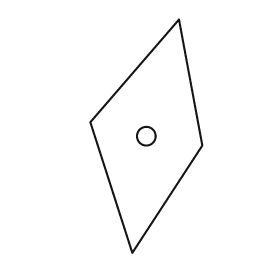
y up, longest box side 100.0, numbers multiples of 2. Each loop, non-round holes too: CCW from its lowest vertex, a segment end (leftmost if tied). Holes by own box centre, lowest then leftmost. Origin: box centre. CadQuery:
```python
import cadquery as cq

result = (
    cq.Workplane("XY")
    .moveTo(-6.0, -50.0)
    .lineTo(24.0, -4.0)
    .lineTo(14.0, 50.0)
    .lineTo(-24.0, 6.0)
    .close()
    .moveTo(0.0, 0.0)
    .circle(4.0)
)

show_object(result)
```